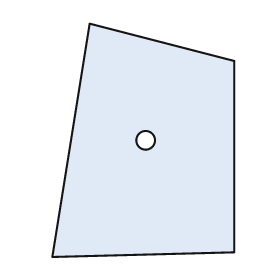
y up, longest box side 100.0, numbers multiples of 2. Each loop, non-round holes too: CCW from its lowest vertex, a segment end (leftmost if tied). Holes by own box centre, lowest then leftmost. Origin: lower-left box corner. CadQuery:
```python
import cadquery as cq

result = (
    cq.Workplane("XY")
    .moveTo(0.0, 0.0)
    .lineTo(78.0, 2.0)
    .lineTo(78.0, 84.0)
    .lineTo(16.0, 100.0)
    .close()
    .moveTo(40.0, 50.0)
    .circle(4.0)
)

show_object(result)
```